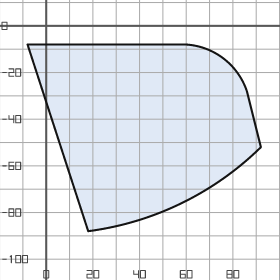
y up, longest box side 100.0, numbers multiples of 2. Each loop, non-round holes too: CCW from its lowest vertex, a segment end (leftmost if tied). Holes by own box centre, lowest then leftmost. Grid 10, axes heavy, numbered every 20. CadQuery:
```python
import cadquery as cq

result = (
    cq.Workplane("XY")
    .moveTo(18.0, -88.0)
    .threePointArc((58.0, -76.0), (92.0, -52.0))
    .lineTo(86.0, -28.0)
    .threePointArc((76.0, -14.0), (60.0, -8.0))
    .lineTo(-8.0, -8.0)
    .close()
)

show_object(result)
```